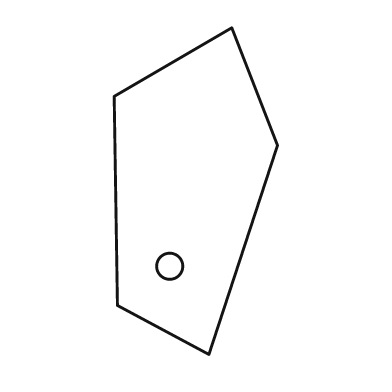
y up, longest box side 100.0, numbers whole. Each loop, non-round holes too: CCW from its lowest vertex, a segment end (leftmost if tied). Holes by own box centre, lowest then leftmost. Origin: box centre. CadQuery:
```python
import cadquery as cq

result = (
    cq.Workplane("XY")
    .moveTo(4.0, -50.0)
    .lineTo(25.0, 14.0)
    .lineTo(11.0, 50.0)
    .lineTo(-25.0, 29.0)
    .lineTo(-24.0, -35.0)
    .close()
    .moveTo(-8.0, -23.0)
    .circle(4.0)
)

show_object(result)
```